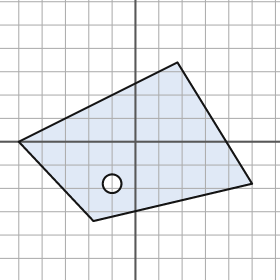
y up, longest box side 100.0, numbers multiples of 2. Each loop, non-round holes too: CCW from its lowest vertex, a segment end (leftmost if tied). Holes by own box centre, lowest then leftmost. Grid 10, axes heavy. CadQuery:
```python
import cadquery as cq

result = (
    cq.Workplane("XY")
    .moveTo(-18.0, -34.0)
    .lineTo(50.0, -18.0)
    .lineTo(18.0, 34.0)
    .lineTo(-50.0, 0.0)
    .close()
    .moveTo(-10.0, -18.0)
    .circle(4.0)
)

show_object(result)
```